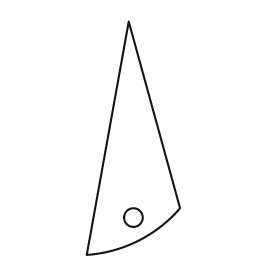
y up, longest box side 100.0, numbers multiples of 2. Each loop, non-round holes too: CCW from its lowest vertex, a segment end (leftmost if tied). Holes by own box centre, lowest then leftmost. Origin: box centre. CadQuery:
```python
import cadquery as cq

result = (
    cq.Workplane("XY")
    .moveTo(-20.0, -50.0)
    .threePointArc((2.0, -44.0), (20.0, -30.0))
    .lineTo(-2.0, 50.0)
    .close()
    .moveTo(0.0, -34.0)
    .circle(4.0)
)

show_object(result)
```